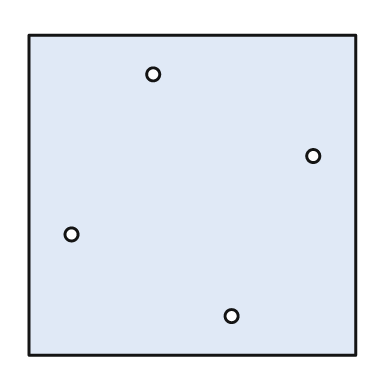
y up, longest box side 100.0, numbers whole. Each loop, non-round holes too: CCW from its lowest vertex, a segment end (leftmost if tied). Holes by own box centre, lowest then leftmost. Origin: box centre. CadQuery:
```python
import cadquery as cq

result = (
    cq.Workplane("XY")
    .moveTo(-50.0, -49.0)
    .lineTo(50.0, -49.0)
    .lineTo(50.0, 49.0)
    .lineTo(-50.0, 49.0)
    .close()
    .moveTo(12.0, -37.0)
    .circle(2.0)
    .moveTo(-37.0, -12.0)
    .circle(2.0)
    .moveTo(37.0, 12.0)
    .circle(2.0)
    .moveTo(-12.0, 37.0)
    .circle(2.0)
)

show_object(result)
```